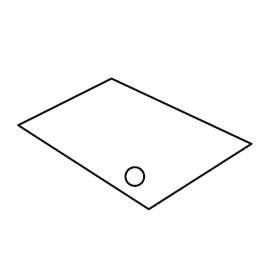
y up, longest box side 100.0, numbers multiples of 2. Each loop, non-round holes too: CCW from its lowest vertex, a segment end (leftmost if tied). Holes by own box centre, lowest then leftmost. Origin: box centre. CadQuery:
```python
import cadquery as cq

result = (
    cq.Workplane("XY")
    .moveTo(6.0, -28.0)
    .lineTo(50.0, 0.0)
    .lineTo(-10.0, 28.0)
    .lineTo(-50.0, 8.0)
    .close()
    .moveTo(0.0, -14.0)
    .circle(4.0)
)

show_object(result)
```